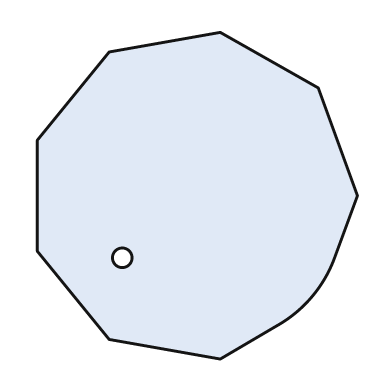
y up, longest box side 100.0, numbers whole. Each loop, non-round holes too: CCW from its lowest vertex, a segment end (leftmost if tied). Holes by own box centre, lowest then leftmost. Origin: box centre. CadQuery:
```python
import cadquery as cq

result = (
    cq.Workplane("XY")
    .moveTo(7.0, -50.0)
    .lineTo(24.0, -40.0)
    .threePointArc((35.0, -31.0), (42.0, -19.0))
    .lineTo(49.0, 0.0)
    .lineTo(37.0, 33.0)
    .lineTo(7.0, 50.0)
    .lineTo(-27.0, 44.0)
    .lineTo(-49.0, 17.0)
    .lineTo(-49.0, -17.0)
    .lineTo(-27.0, -44.0)
    .close()
    .moveTo(-23.0, -19.0)
    .circle(3.0)
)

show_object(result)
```